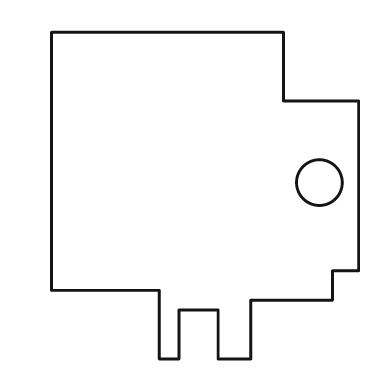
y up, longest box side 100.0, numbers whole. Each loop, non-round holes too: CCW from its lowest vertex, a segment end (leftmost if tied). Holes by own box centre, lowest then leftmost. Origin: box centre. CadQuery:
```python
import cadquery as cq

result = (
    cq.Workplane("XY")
    .moveTo(-14.0, -50.0)
    .lineTo(-8.0, -50.0)
    .lineTo(-8.0, -35.0)
    .lineTo(4.0, -35.0)
    .lineTo(4.0, -50.0)
    .lineTo(14.0, -50.0)
    .lineTo(14.0, -32.0)
    .lineTo(39.0, -32.0)
    .lineTo(39.0, -23.0)
    .lineTo(47.0, -23.0)
    .lineTo(47.0, 29.0)
    .lineTo(24.0, 29.0)
    .lineTo(24.0, 50.0)
    .lineTo(-47.0, 50.0)
    .lineTo(-47.0, -29.0)
    .lineTo(-14.0, -29.0)
    .close()
    .moveTo(35.0, 4.0)
    .circle(7.0)
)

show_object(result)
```